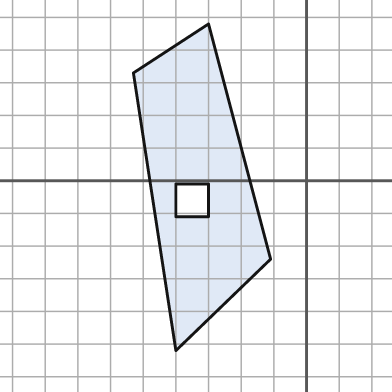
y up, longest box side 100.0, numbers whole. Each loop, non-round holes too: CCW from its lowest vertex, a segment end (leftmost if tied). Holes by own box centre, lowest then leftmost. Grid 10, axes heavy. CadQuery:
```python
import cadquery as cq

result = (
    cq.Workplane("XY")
    .moveTo(-40.0, -52.0)
    .lineTo(-11.0, -24.0)
    .lineTo(-30.0, 48.0)
    .lineTo(-53.0, 33.0)
    .close()
    .moveTo(-40.0, -11.0)
    .lineTo(-30.0, -11.0)
    .lineTo(-30.0, -1.0)
    .lineTo(-40.0, -1.0)
    .close()
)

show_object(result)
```